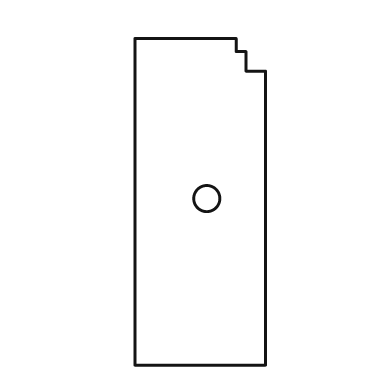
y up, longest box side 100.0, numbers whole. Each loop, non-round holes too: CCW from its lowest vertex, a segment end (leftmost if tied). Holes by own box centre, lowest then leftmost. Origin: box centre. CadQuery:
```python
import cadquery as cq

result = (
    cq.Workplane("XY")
    .moveTo(-20.0, -50.0)
    .lineTo(20.0, -50.0)
    .lineTo(20.0, 40.0)
    .lineTo(14.0, 40.0)
    .lineTo(14.0, 46.0)
    .lineTo(11.0, 46.0)
    .lineTo(11.0, 50.0)
    .lineTo(-20.0, 50.0)
    .close()
    .moveTo(2.0, 1.0)
    .circle(4.0)
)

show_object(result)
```